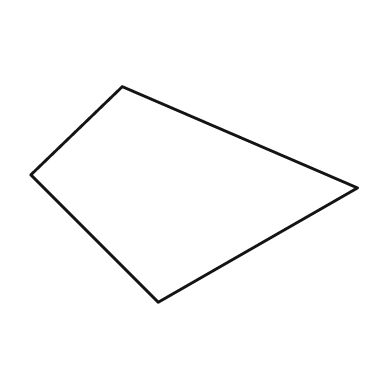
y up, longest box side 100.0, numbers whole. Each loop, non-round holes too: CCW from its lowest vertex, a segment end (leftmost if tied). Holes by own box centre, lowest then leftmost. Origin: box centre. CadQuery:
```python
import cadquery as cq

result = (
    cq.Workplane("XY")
    .moveTo(-11.0, -33.0)
    .lineTo(50.0, 2.0)
    .lineTo(-22.0, 33.0)
    .lineTo(-50.0, 6.0)
    .close()
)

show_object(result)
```